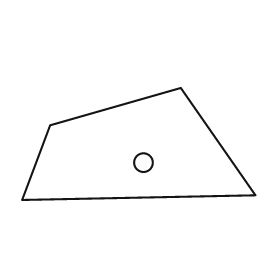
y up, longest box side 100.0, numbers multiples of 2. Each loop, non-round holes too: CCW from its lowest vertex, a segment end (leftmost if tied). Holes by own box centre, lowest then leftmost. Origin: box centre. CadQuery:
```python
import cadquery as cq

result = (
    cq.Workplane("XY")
    .moveTo(-50.0, -24.0)
    .lineTo(50.0, -22.0)
    .lineTo(18.0, 24.0)
    .lineTo(-38.0, 8.0)
    .close()
    .moveTo(2.0, -8.0)
    .circle(4.0)
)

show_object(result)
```